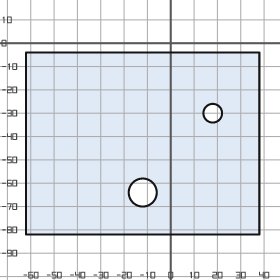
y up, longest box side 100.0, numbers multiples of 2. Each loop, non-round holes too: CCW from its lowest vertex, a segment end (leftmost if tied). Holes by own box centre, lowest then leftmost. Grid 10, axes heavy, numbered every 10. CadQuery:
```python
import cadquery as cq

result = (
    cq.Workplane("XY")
    .moveTo(-62.0, -82.0)
    .lineTo(38.0, -82.0)
    .lineTo(38.0, -4.0)
    .lineTo(-62.0, -4.0)
    .close()
    .moveTo(-12.0, -64.0)
    .circle(6.0)
    .moveTo(18.0, -30.0)
    .circle(4.0)
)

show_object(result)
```